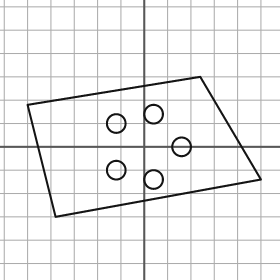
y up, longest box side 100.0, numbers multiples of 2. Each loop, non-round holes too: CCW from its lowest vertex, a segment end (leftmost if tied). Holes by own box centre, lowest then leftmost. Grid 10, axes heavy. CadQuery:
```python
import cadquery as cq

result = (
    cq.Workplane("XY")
    .moveTo(-38.0, -30.0)
    .lineTo(50.0, -14.0)
    .lineTo(24.0, 30.0)
    .lineTo(-50.0, 18.0)
    .close()
    .moveTo(4.0, -14.0)
    .circle(4.0)
    .moveTo(-12.0, -10.0)
    .circle(4.0)
    .moveTo(16.0, 0.0)
    .circle(4.0)
    .moveTo(-12.0, 10.0)
    .circle(4.0)
    .moveTo(4.0, 14.0)
    .circle(4.0)
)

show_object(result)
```